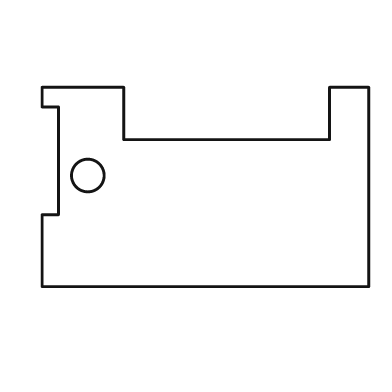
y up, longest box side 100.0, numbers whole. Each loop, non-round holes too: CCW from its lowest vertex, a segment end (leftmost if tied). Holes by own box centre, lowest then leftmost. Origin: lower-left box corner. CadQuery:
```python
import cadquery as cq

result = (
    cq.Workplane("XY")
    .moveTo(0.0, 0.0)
    .lineTo(100.0, 0.0)
    .lineTo(100.0, 61.0)
    .lineTo(88.0, 61.0)
    .lineTo(88.0, 45.0)
    .lineTo(25.0, 45.0)
    .lineTo(25.0, 61.0)
    .lineTo(0.0, 61.0)
    .lineTo(0.0, 55.0)
    .lineTo(5.0, 55.0)
    .lineTo(5.0, 22.0)
    .lineTo(0.0, 22.0)
    .close()
    .moveTo(14.0, 34.0)
    .circle(5.0)
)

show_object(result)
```